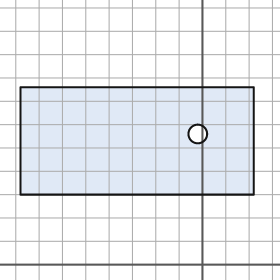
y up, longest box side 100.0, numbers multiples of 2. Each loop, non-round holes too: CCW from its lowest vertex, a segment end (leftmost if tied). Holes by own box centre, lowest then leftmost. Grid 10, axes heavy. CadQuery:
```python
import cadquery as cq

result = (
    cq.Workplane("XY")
    .moveTo(-78.0, 30.0)
    .lineTo(22.0, 30.0)
    .lineTo(22.0, 76.0)
    .lineTo(-78.0, 76.0)
    .close()
    .moveTo(-2.0, 56.0)
    .circle(4.0)
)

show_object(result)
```